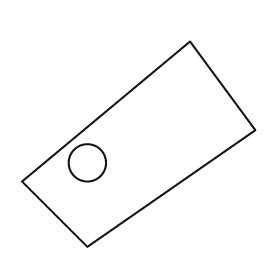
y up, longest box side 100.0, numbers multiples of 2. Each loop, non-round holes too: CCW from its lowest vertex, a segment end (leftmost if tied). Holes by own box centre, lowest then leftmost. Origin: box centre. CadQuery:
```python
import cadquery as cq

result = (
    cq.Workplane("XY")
    .moveTo(-22.0, -44.0)
    .lineTo(50.0, 6.0)
    .lineTo(22.0, 44.0)
    .lineTo(-50.0, -16.0)
    .close()
    .moveTo(-22.0, -8.0)
    .circle(8.0)
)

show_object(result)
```